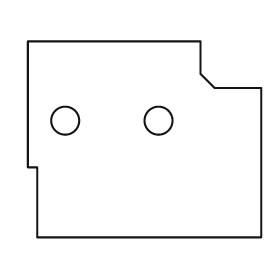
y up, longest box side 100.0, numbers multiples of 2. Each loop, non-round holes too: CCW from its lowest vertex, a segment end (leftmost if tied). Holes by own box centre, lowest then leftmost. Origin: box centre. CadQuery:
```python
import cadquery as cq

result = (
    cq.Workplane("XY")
    .moveTo(-46.0, -42.0)
    .lineTo(50.0, -42.0)
    .lineTo(50.0, 22.0)
    .lineTo(30.0, 22.0)
    .lineTo(24.0, 28.0)
    .lineTo(24.0, 42.0)
    .lineTo(-50.0, 42.0)
    .lineTo(-50.0, -12.0)
    .lineTo(-46.0, -12.0)
    .close()
    .moveTo(-34.0, 8.0)
    .circle(6.0)
    .moveTo(6.0, 8.0)
    .circle(6.0)
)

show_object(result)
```